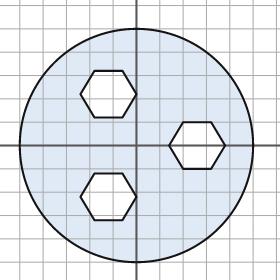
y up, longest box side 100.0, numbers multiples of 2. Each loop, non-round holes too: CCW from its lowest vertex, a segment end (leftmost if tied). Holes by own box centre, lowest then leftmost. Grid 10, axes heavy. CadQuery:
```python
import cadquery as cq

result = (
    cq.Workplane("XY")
    .moveTo(0.0, 0.0)
    .circle(50.0)
    .moveTo(-18.0, -32.0)
    .lineTo(-6.0, -32.0)
    .lineTo(0.0, -22.0)
    .lineTo(-6.0, -12.0)
    .lineTo(-18.0, -12.0)
    .lineTo(-24.0, -22.0)
    .close()
    .moveTo(20.0, -10.0)
    .lineTo(32.0, -10.0)
    .lineTo(38.0, 0.0)
    .lineTo(32.0, 10.0)
    .lineTo(20.0, 10.0)
    .lineTo(14.0, 0.0)
    .close()
    .moveTo(-18.0, 12.0)
    .lineTo(-6.0, 12.0)
    .lineTo(0.0, 22.0)
    .lineTo(-6.0, 32.0)
    .lineTo(-18.0, 32.0)
    .lineTo(-24.0, 22.0)
    .close()
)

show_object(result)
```